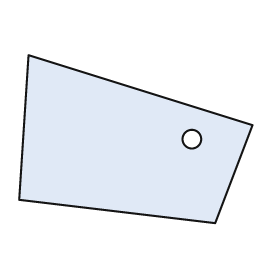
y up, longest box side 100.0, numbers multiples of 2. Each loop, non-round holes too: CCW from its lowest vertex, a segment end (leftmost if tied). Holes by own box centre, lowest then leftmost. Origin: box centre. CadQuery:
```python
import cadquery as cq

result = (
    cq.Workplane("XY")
    .moveTo(34.0, -36.0)
    .lineTo(50.0, 6.0)
    .lineTo(-46.0, 36.0)
    .lineTo(-50.0, -26.0)
    .close()
    .moveTo(24.0, 0.0)
    .circle(4.0)
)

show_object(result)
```